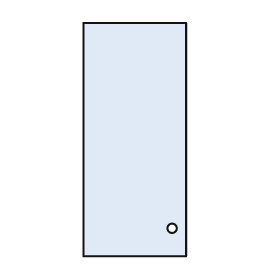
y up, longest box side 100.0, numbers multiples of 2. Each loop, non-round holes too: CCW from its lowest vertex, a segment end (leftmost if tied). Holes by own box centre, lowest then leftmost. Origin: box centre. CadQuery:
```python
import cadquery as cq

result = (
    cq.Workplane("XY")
    .moveTo(-22.0, -50.0)
    .lineTo(22.0, -50.0)
    .lineTo(22.0, 50.0)
    .lineTo(-22.0, 50.0)
    .close()
    .moveTo(16.0, -38.0)
    .circle(2.0)
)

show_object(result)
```